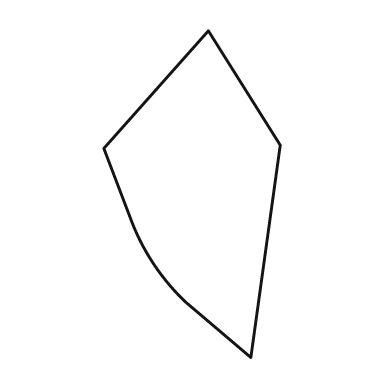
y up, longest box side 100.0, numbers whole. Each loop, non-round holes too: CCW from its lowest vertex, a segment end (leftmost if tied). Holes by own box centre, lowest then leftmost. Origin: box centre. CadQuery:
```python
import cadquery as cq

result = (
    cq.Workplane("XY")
    .moveTo(18.0, -50.0)
    .lineTo(27.0, 15.0)
    .lineTo(5.0, 50.0)
    .lineTo(-27.0, 14.0)
    .lineTo(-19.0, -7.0)
    .threePointArc((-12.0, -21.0), (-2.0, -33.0))
    .close()
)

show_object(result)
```